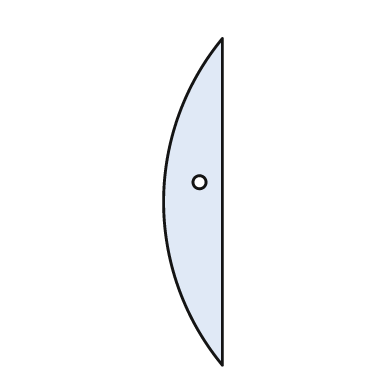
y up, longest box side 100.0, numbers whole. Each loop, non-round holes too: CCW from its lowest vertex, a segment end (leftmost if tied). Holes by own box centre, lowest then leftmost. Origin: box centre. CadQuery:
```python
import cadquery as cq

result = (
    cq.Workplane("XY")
    .moveTo(9.0, -50.0)
    .lineTo(9.0, 50.0)
    .threePointArc((-9.0, 0.0), (9.0, -50.0))
    .close()
    .moveTo(2.0, 6.0)
    .circle(2.0)
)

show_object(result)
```